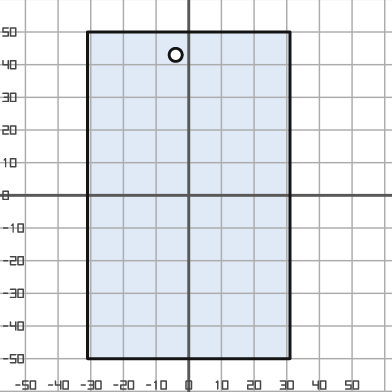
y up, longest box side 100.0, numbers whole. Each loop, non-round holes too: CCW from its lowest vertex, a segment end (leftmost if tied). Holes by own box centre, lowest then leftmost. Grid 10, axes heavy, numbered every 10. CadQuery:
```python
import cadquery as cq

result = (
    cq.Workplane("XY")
    .moveTo(-31.0, -50.0)
    .lineTo(31.0, -50.0)
    .lineTo(31.0, 50.0)
    .lineTo(-31.0, 50.0)
    .close()
    .moveTo(-4.0, 43.0)
    .circle(2.0)
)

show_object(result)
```